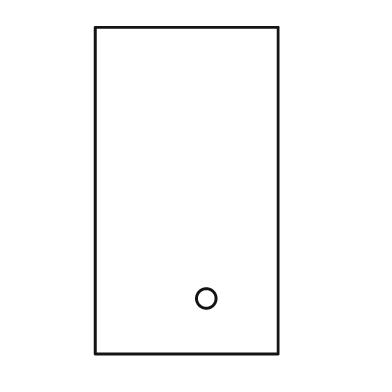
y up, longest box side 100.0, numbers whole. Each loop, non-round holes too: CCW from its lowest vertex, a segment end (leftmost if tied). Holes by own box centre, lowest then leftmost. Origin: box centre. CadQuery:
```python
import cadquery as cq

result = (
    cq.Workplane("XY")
    .moveTo(-28.0, -50.0)
    .lineTo(28.0, -50.0)
    .lineTo(28.0, 50.0)
    .lineTo(-28.0, 50.0)
    .close()
    .moveTo(6.0, -33.0)
    .circle(3.0)
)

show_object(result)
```